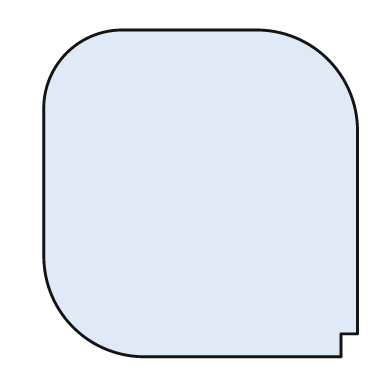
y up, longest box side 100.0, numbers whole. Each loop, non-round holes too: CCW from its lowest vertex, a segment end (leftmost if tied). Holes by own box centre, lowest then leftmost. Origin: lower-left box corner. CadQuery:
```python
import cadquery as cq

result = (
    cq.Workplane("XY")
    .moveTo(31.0, 0.0)
    .lineTo(91.0, 0.0)
    .lineTo(91.0, 7.0)
    .lineTo(96.0, 7.0)
    .lineTo(96.0, 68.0)
    .threePointArc((87.0, 91.0), (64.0, 100.0))
    .lineTo(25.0, 100.0)
    .threePointArc((7.0, 93.0), (0.0, 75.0))
    .lineTo(0.0, 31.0)
    .threePointArc((9.0, 9.0), (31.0, 0.0))
    .close()
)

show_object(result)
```